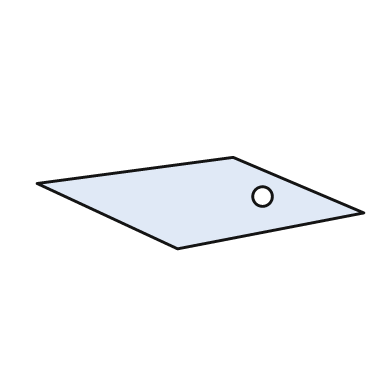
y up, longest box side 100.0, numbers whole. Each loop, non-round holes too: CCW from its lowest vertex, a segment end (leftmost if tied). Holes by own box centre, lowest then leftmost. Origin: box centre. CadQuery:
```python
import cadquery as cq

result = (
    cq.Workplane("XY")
    .moveTo(-7.0, -14.0)
    .lineTo(50.0, -3.0)
    .lineTo(10.0, 14.0)
    .lineTo(-50.0, 6.0)
    .close()
    .moveTo(19.0, 2.0)
    .circle(3.0)
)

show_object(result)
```